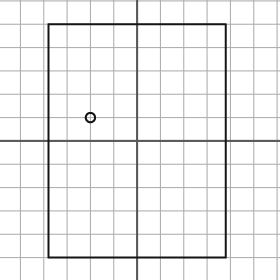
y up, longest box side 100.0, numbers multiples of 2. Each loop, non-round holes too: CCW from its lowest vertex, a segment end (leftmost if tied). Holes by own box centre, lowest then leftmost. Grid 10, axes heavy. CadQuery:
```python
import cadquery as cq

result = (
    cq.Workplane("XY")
    .moveTo(-38.0, -50.0)
    .lineTo(38.0, -50.0)
    .lineTo(38.0, 50.0)
    .lineTo(-38.0, 50.0)
    .close()
    .moveTo(-20.0, 10.0)
    .circle(2.0)
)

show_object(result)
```